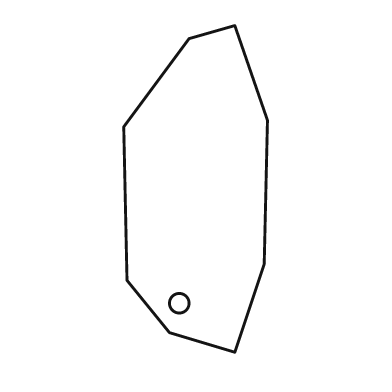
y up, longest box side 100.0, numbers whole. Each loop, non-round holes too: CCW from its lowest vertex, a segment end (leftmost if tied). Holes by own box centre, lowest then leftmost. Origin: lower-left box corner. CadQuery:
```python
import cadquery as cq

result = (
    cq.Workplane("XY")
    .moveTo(34.0, 0.0)
    .lineTo(43.0, 27.0)
    .lineTo(44.0, 71.0)
    .lineTo(34.0, 100.0)
    .lineTo(20.0, 96.0)
    .lineTo(0.0, 69.0)
    .lineTo(1.0, 22.0)
    .lineTo(14.0, 6.0)
    .close()
    .moveTo(17.0, 15.0)
    .circle(3.0)
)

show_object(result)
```